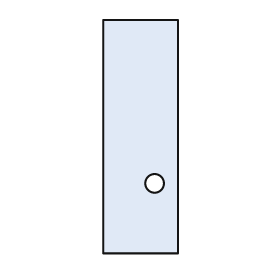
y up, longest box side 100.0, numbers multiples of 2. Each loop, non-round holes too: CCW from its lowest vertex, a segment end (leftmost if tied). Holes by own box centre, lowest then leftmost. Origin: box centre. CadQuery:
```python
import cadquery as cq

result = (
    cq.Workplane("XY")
    .moveTo(-16.0, -50.0)
    .lineTo(16.0, -50.0)
    .lineTo(16.0, 50.0)
    .lineTo(-16.0, 50.0)
    .close()
    .moveTo(6.0, -20.0)
    .circle(4.0)
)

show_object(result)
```